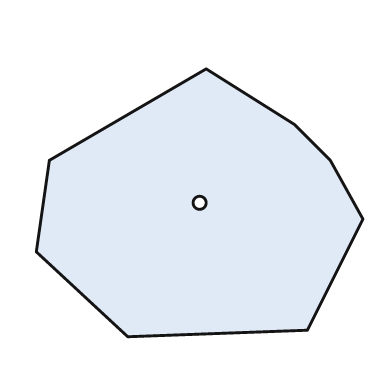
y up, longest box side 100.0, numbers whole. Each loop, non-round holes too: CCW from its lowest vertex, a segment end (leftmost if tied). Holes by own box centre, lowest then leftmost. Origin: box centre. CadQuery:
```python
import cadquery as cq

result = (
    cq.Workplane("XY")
    .moveTo(-22.0, -41.0)
    .lineTo(33.0, -39.0)
    .lineTo(50.0, -5.0)
    .lineTo(40.0, 13.0)
    .lineTo(29.0, 24.0)
    .lineTo(2.0, 41.0)
    .lineTo(-46.0, 13.0)
    .lineTo(-50.0, -15.0)
    .close()
    .moveTo(0.0, 0.0)
    .circle(2.0)
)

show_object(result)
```